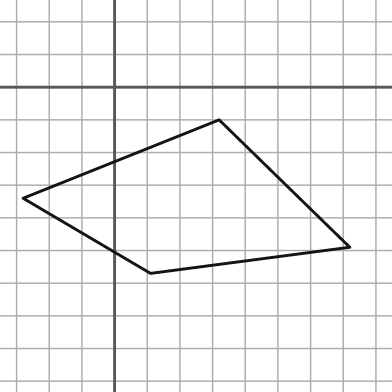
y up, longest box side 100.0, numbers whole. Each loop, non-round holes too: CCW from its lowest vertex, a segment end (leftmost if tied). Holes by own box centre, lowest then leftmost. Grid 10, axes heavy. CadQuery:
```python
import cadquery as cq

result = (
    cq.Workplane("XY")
    .moveTo(11.0, -57.0)
    .lineTo(72.0, -49.0)
    .lineTo(32.0, -10.0)
    .lineTo(-28.0, -34.0)
    .close()
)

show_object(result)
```